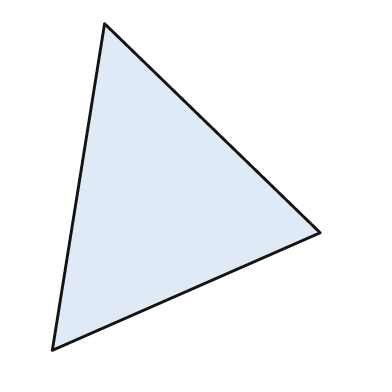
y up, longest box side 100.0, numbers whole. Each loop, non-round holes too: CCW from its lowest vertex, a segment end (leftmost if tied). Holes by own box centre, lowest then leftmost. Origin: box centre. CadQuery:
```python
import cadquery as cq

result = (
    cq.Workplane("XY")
    .moveTo(-41.0, -50.0)
    .lineTo(41.0, -14.0)
    .lineTo(-25.0, 50.0)
    .close()
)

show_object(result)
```